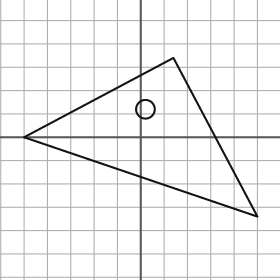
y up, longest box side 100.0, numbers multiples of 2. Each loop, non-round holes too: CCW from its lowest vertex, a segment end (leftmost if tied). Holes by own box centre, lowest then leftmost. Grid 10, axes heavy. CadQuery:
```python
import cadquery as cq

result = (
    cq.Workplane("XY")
    .moveTo(50.0, -34.0)
    .lineTo(14.0, 34.0)
    .lineTo(-50.0, 0.0)
    .close()
    .moveTo(2.0, 12.0)
    .circle(4.0)
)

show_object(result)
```